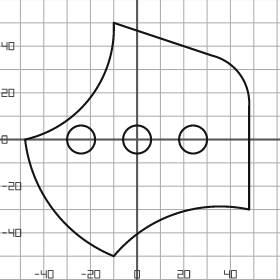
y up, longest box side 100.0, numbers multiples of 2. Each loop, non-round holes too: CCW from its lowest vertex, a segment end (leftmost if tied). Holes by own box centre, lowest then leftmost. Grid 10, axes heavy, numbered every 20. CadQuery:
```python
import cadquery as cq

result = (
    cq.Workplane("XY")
    .moveTo(-10.0, -50.0)
    .threePointArc((16.0, -32.0), (48.0, -30.0))
    .lineTo(48.0, 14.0)
    .threePointArc((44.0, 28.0), (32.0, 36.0))
    .lineTo(-10.0, 50.0)
    .threePointArc((-20.0, 18.0), (-48.0, 0.0))
    .threePointArc((-36.0, -30.0), (-10.0, -50.0))
    .close()
    .moveTo(-24.0, 0.0)
    .circle(6.0)
    .moveTo(0.0, 0.0)
    .circle(6.0)
    .moveTo(24.0, 0.0)
    .circle(6.0)
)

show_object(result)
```